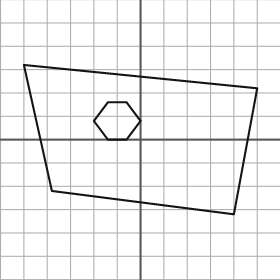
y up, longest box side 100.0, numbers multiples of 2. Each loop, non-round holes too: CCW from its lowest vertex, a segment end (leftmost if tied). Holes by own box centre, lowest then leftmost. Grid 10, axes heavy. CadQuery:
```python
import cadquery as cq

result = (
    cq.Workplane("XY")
    .moveTo(40.0, -32.0)
    .lineTo(50.0, 22.0)
    .lineTo(-50.0, 32.0)
    .lineTo(-38.0, -22.0)
    .close()
    .moveTo(-14.0, 0.0)
    .lineTo(-6.0, 0.0)
    .lineTo(0.0, 8.0)
    .lineTo(-6.0, 16.0)
    .lineTo(-14.0, 16.0)
    .lineTo(-20.0, 8.0)
    .close()
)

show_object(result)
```